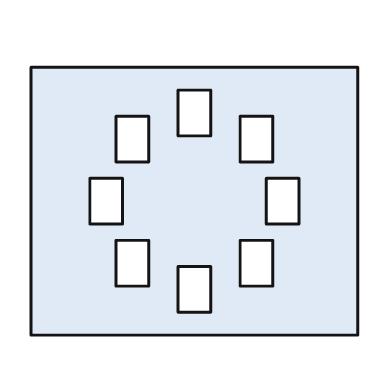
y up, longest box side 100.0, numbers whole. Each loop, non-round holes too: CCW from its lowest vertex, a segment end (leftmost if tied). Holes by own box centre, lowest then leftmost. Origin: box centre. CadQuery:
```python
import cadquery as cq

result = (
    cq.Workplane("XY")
    .moveTo(-50.0, -41.0)
    .lineTo(50.0, -41.0)
    .lineTo(50.0, 41.0)
    .lineTo(-50.0, 41.0)
    .close()
    .moveTo(-5.0, -34.0)
    .lineTo(5.0, -34.0)
    .lineTo(5.0, -20.0)
    .lineTo(-5.0, -20.0)
    .close()
    .moveTo(-24.0, -26.0)
    .lineTo(-14.0, -26.0)
    .lineTo(-14.0, -12.0)
    .lineTo(-24.0, -12.0)
    .close()
    .moveTo(14.0, -26.0)
    .lineTo(24.0, -26.0)
    .lineTo(24.0, -12.0)
    .lineTo(14.0, -12.0)
    .close()
    .moveTo(-32.0, -7.0)
    .lineTo(-22.0, -7.0)
    .lineTo(-22.0, 7.0)
    .lineTo(-32.0, 7.0)
    .close()
    .moveTo(22.0, -7.0)
    .lineTo(32.0, -7.0)
    .lineTo(32.0, 7.0)
    .lineTo(22.0, 7.0)
    .close()
    .moveTo(-24.0, 12.0)
    .lineTo(-14.0, 12.0)
    .lineTo(-14.0, 26.0)
    .lineTo(-24.0, 26.0)
    .close()
    .moveTo(14.0, 12.0)
    .lineTo(24.0, 12.0)
    .lineTo(24.0, 26.0)
    .lineTo(14.0, 26.0)
    .close()
    .moveTo(-5.0, 20.0)
    .lineTo(5.0, 20.0)
    .lineTo(5.0, 34.0)
    .lineTo(-5.0, 34.0)
    .close()
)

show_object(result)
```